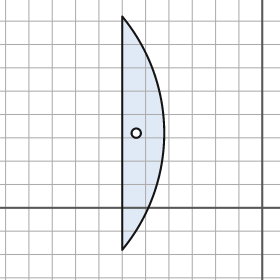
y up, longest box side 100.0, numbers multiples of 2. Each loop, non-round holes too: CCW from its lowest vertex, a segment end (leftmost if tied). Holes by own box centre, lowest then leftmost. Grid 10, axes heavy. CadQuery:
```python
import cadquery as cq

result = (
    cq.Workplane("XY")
    .moveTo(-60.0, -18.0)
    .threePointArc((-42.0, 32.0), (-60.0, 82.0))
    .close()
    .moveTo(-54.0, 32.0)
    .circle(2.0)
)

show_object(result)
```